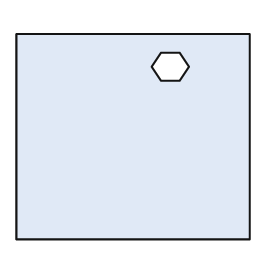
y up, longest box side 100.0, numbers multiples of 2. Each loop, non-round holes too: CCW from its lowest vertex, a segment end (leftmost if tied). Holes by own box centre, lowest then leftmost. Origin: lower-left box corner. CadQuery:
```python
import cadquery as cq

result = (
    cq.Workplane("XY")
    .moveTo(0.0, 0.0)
    .lineTo(100.0, 0.0)
    .lineTo(100.0, 88.0)
    .lineTo(0.0, 88.0)
    .close()
    .moveTo(62.0, 68.0)
    .lineTo(70.0, 68.0)
    .lineTo(74.0, 74.0)
    .lineTo(70.0, 80.0)
    .lineTo(62.0, 80.0)
    .lineTo(58.0, 74.0)
    .close()
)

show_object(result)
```